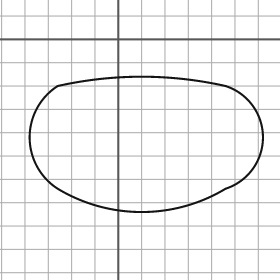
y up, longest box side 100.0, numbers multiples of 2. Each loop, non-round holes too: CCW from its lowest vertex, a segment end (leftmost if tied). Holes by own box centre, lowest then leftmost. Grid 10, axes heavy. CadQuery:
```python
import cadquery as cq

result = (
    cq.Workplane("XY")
    .moveTo(-26.0, -64.0)
    .threePointArc((10.0, -74.0), (46.0, -64.0))
    .threePointArc((62.0, -42.0), (46.0, -20.0))
    .threePointArc((10.0, -16.0), (-26.0, -20.0))
    .threePointArc((-38.0, -42.0), (-26.0, -64.0))
    .close()
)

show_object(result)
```